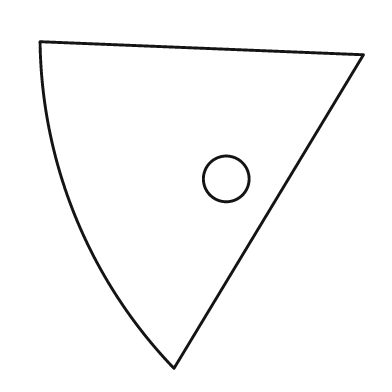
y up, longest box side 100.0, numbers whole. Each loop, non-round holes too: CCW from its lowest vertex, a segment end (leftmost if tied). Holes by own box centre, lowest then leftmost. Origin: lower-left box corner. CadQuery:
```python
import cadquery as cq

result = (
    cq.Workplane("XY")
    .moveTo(41.0, 0.0)
    .lineTo(99.0, 96.0)
    .lineTo(0.0, 100.0)
    .threePointArc((11.0, 46.0), (41.0, 0.0))
    .close()
    .moveTo(57.0, 58.0)
    .circle(7.0)
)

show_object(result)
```